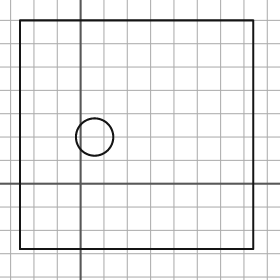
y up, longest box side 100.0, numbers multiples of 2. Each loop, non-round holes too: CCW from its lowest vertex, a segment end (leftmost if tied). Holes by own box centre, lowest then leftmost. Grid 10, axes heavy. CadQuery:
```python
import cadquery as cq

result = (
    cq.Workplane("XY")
    .moveTo(-26.0, -28.0)
    .lineTo(74.0, -28.0)
    .lineTo(74.0, 70.0)
    .lineTo(-26.0, 70.0)
    .close()
    .moveTo(6.0, 20.0)
    .circle(8.0)
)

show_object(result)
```